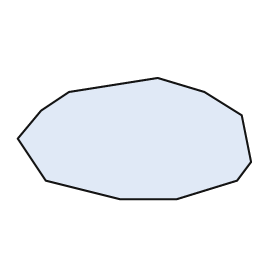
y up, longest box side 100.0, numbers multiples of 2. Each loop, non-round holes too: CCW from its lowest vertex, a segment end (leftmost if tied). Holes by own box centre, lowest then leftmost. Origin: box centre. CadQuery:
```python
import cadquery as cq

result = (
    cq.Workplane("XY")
    .moveTo(-6.0, -26.0)
    .lineTo(18.0, -26.0)
    .lineTo(44.0, -18.0)
    .lineTo(50.0, -10.0)
    .lineTo(46.0, 10.0)
    .lineTo(30.0, 20.0)
    .lineTo(10.0, 26.0)
    .lineTo(-28.0, 20.0)
    .lineTo(-40.0, 12.0)
    .lineTo(-50.0, 0.0)
    .lineTo(-38.0, -18.0)
    .close()
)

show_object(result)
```